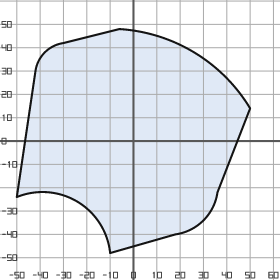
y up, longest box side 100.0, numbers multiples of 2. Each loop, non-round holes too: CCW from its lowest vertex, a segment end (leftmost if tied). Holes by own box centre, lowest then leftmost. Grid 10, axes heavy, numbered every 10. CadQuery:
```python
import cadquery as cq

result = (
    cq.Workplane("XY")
    .moveTo(-10.0, -48.0)
    .lineTo(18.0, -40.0)
    .threePointArc((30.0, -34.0), (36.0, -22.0))
    .lineTo(50.0, 14.0)
    .threePointArc((26.0, 38.0), (-6.0, 48.0))
    .lineTo(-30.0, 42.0)
    .threePointArc((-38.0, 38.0), (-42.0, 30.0))
    .lineTo(-50.0, -24.0)
    .threePointArc((-24.0, -26.0), (-10.0, -48.0))
    .close()
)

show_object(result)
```